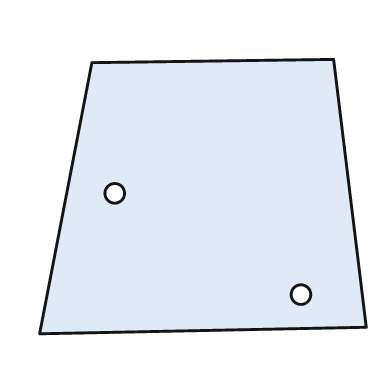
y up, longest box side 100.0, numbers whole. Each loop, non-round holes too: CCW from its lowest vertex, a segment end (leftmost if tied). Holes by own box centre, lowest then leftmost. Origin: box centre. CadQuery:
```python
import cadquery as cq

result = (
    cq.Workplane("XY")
    .moveTo(-50.0, -42.0)
    .lineTo(50.0, -40.0)
    .lineTo(40.0, 42.0)
    .lineTo(-34.0, 41.0)
    .close()
    .moveTo(30.0, -30.0)
    .circle(3.0)
    .moveTo(-27.0, 1.0)
    .circle(3.0)
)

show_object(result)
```